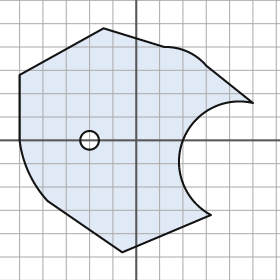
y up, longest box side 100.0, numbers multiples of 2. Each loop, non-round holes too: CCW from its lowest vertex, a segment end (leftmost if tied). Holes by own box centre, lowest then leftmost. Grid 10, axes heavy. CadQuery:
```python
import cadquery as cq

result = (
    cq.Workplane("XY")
    .moveTo(-6.0, -48.0)
    .lineTo(32.0, -32.0)
    .threePointArc((20.0, 0.0), (50.0, 16.0))
    .lineTo(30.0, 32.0)
    .threePointArc((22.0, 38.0), (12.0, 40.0))
    .lineTo(-14.0, 48.0)
    .lineTo(-50.0, 28.0)
    .lineTo(-50.0, 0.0)
    .threePointArc((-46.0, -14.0), (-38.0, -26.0))
    .close()
    .moveTo(-20.0, 0.0)
    .circle(4.0)
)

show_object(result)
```